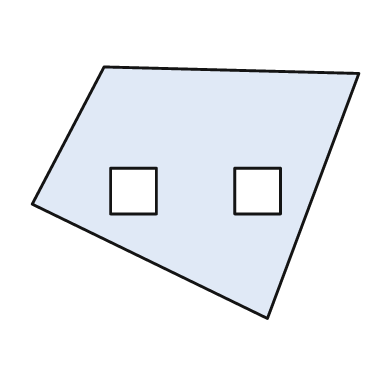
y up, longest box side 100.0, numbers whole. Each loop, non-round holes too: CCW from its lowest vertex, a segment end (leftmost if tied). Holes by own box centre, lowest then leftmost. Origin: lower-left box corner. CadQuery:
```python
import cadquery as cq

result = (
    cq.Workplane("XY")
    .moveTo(72.0, 0.0)
    .lineTo(100.0, 75.0)
    .lineTo(22.0, 77.0)
    .lineTo(0.0, 35.0)
    .close()
    .moveTo(24.0, 32.0)
    .lineTo(38.0, 32.0)
    .lineTo(38.0, 46.0)
    .lineTo(24.0, 46.0)
    .close()
    .moveTo(62.0, 32.0)
    .lineTo(76.0, 32.0)
    .lineTo(76.0, 46.0)
    .lineTo(62.0, 46.0)
    .close()
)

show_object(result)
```